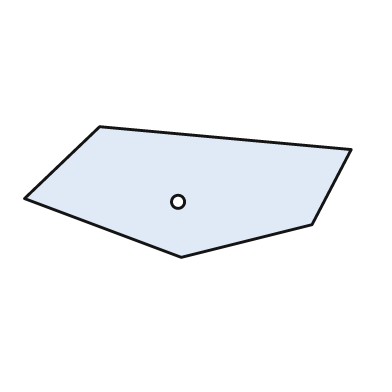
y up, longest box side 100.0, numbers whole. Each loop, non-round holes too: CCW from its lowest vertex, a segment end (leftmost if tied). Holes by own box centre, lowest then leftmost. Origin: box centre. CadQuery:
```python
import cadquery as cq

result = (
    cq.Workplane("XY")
    .moveTo(-2.0, -20.0)
    .lineTo(38.0, -10.0)
    .lineTo(50.0, 13.0)
    .lineTo(-27.0, 20.0)
    .lineTo(-50.0, -2.0)
    .close()
    .moveTo(-3.0, -3.0)
    .circle(2.0)
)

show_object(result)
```